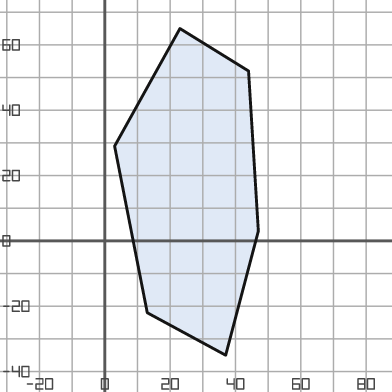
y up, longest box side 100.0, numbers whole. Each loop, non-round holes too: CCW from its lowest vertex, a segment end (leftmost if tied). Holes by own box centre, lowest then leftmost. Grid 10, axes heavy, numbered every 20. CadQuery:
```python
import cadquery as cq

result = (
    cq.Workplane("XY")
    .moveTo(37.0, -35.0)
    .lineTo(47.0, 3.0)
    .lineTo(44.0, 52.0)
    .lineTo(23.0, 65.0)
    .lineTo(3.0, 29.0)
    .lineTo(13.0, -22.0)
    .close()
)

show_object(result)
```